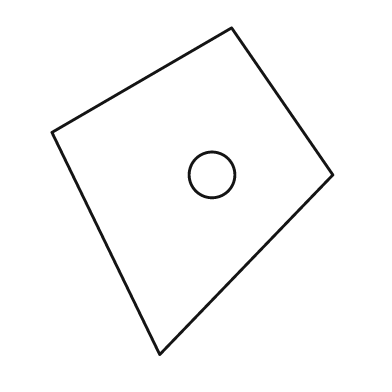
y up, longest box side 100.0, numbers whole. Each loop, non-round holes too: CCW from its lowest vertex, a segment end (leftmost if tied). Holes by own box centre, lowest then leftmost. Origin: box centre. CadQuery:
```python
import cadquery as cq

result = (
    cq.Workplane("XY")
    .moveTo(-10.0, -50.0)
    .lineTo(43.0, 5.0)
    .lineTo(12.0, 50.0)
    .lineTo(-43.0, 18.0)
    .close()
    .moveTo(6.0, 5.0)
    .circle(7.0)
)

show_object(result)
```